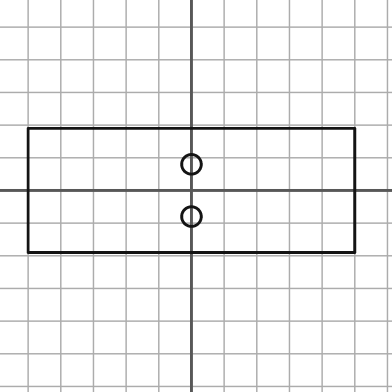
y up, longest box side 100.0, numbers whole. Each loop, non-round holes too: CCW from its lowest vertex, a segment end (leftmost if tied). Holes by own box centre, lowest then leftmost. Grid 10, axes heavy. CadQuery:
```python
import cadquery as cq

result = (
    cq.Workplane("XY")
    .moveTo(-50.0, -19.0)
    .lineTo(50.0, -19.0)
    .lineTo(50.0, 19.0)
    .lineTo(-50.0, 19.0)
    .close()
    .moveTo(0.0, -8.0)
    .circle(3.0)
    .moveTo(0.0, 8.0)
    .circle(3.0)
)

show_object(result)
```